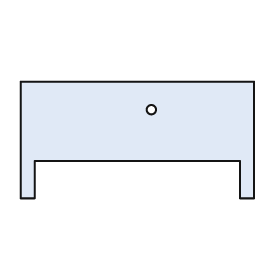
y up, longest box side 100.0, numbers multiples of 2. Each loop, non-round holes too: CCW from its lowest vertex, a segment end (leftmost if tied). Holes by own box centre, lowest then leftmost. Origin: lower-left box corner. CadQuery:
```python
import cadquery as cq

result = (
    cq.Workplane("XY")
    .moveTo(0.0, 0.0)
    .lineTo(6.0, 0.0)
    .lineTo(6.0, 16.0)
    .lineTo(94.0, 16.0)
    .lineTo(94.0, 0.0)
    .lineTo(100.0, 0.0)
    .lineTo(100.0, 50.0)
    .lineTo(0.0, 50.0)
    .close()
    .moveTo(56.0, 38.0)
    .circle(2.0)
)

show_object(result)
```